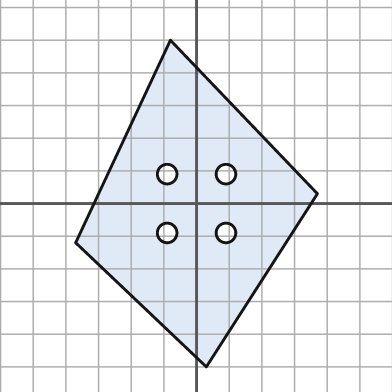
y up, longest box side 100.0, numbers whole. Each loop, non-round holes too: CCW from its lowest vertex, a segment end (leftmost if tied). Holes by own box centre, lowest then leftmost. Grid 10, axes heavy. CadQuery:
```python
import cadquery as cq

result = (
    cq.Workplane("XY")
    .moveTo(3.0, -50.0)
    .lineTo(37.0, 3.0)
    .lineTo(-8.0, 50.0)
    .lineTo(-37.0, -12.0)
    .close()
    .moveTo(-9.0, -9.0)
    .circle(3.0)
    .moveTo(9.0, -9.0)
    .circle(3.0)
    .moveTo(-9.0, 9.0)
    .circle(3.0)
    .moveTo(9.0, 9.0)
    .circle(3.0)
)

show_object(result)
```